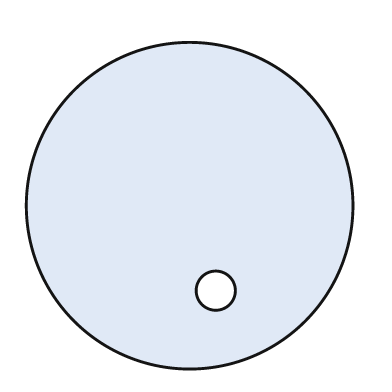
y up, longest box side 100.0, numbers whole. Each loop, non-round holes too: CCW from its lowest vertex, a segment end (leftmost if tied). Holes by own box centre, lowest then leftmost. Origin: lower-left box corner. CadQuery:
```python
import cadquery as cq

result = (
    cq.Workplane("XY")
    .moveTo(50.0, 50.0)
    .circle(50.0)
    .moveTo(58.0, 24.0)
    .circle(6.0)
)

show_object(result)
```